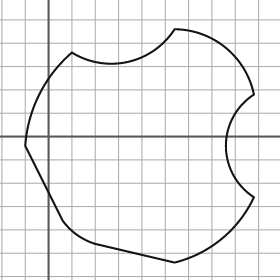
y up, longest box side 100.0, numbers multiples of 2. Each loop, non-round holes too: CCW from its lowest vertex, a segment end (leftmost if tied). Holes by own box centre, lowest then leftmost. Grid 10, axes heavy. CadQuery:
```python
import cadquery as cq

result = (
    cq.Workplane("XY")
    .moveTo(54.0, -54.0)
    .threePointArc((74.0, -44.0), (88.0, -26.0))
    .threePointArc((76.0, -4.0), (88.0, 18.0))
    .threePointArc((76.0, 38.0), (54.0, 46.0))
    .threePointArc((34.0, 32.0), (10.0, 36.0))
    .threePointArc((-4.0, 18.0), (-10.0, -4.0))
    .lineTo(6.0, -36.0)
    .threePointArc((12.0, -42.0), (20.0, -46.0))
    .close()
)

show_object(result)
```